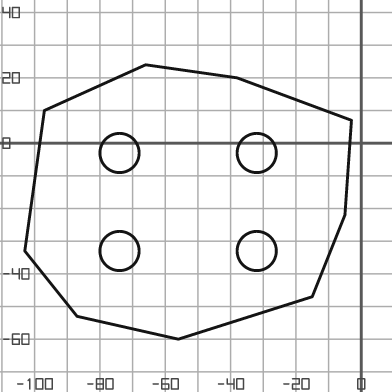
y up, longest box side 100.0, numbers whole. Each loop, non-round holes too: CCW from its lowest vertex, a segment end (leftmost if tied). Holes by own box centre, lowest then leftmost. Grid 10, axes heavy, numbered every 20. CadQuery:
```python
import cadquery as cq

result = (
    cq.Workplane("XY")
    .moveTo(-56.0, -60.0)
    .lineTo(-15.0, -47.0)
    .lineTo(-5.0, -22.0)
    .lineTo(-3.0, 7.0)
    .lineTo(-38.0, 20.0)
    .lineTo(-66.0, 24.0)
    .lineTo(-97.0, 10.0)
    .lineTo(-103.0, -33.0)
    .lineTo(-87.0, -53.0)
    .close()
    .moveTo(-74.0, -33.0)
    .circle(6.0)
    .moveTo(-32.0, -33.0)
    .circle(6.0)
    .moveTo(-74.0, -3.0)
    .circle(6.0)
    .moveTo(-32.0, -3.0)
    .circle(6.0)
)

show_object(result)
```